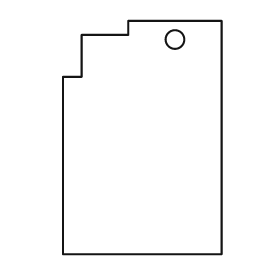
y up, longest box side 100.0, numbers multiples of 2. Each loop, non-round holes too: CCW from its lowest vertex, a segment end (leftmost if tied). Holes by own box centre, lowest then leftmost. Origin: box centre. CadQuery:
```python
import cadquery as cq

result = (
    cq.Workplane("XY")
    .moveTo(-34.0, -50.0)
    .lineTo(34.0, -50.0)
    .lineTo(34.0, 50.0)
    .lineTo(-6.0, 50.0)
    .lineTo(-6.0, 44.0)
    .lineTo(-26.0, 44.0)
    .lineTo(-26.0, 26.0)
    .lineTo(-34.0, 26.0)
    .close()
    .moveTo(14.0, 42.0)
    .circle(4.0)
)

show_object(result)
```